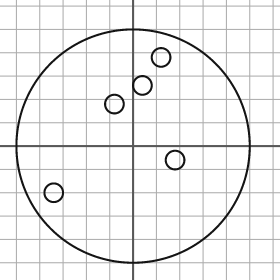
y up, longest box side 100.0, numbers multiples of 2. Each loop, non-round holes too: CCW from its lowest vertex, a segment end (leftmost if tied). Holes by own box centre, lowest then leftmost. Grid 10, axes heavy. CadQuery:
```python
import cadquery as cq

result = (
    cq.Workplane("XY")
    .moveTo(0.0, 0.0)
    .circle(50.0)
    .moveTo(-34.0, -20.0)
    .circle(4.0)
    .moveTo(18.0, -6.0)
    .circle(4.0)
    .moveTo(-8.0, 18.0)
    .circle(4.0)
    .moveTo(4.0, 26.0)
    .circle(4.0)
    .moveTo(12.0, 38.0)
    .circle(4.0)
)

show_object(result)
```